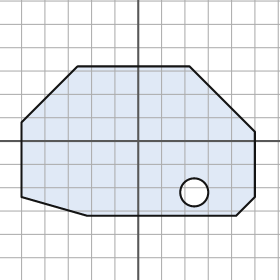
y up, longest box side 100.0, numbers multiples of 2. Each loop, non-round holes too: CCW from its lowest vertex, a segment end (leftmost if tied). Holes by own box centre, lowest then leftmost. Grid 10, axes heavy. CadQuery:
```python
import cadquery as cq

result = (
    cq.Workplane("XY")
    .moveTo(-22.0, -32.0)
    .lineTo(42.0, -32.0)
    .lineTo(50.0, -24.0)
    .lineTo(50.0, 4.0)
    .lineTo(22.0, 32.0)
    .lineTo(-26.0, 32.0)
    .lineTo(-50.0, 8.0)
    .lineTo(-50.0, -24.0)
    .close()
    .moveTo(24.0, -22.0)
    .circle(6.0)
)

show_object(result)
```